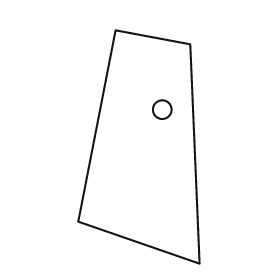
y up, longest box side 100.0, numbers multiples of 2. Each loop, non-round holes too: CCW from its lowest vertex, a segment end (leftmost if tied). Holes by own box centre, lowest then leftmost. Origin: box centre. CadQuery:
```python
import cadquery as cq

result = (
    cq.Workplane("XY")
    .moveTo(26.0, -50.0)
    .lineTo(22.0, 44.0)
    .lineTo(-10.0, 50.0)
    .lineTo(-26.0, -32.0)
    .close()
    .moveTo(10.0, 16.0)
    .circle(4.0)
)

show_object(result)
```